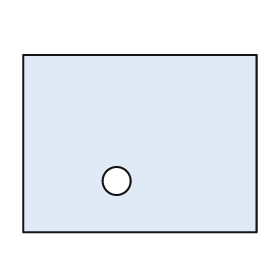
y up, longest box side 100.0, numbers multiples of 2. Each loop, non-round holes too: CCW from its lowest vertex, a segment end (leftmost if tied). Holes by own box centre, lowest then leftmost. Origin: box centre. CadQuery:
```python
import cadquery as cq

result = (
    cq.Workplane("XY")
    .moveTo(-50.0, -38.0)
    .lineTo(50.0, -38.0)
    .lineTo(50.0, 38.0)
    .lineTo(-50.0, 38.0)
    .close()
    .moveTo(-10.0, -16.0)
    .circle(6.0)
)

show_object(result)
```